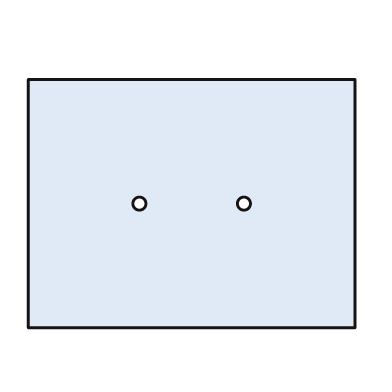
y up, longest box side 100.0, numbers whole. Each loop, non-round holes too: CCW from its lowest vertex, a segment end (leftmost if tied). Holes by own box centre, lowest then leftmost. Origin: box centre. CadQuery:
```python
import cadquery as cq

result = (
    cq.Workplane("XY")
    .moveTo(-50.0, -38.0)
    .lineTo(50.0, -38.0)
    .lineTo(50.0, 38.0)
    .lineTo(-50.0, 38.0)
    .close()
    .moveTo(-16.0, 0.0)
    .circle(2.0)
    .moveTo(16.0, 0.0)
    .circle(2.0)
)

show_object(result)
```